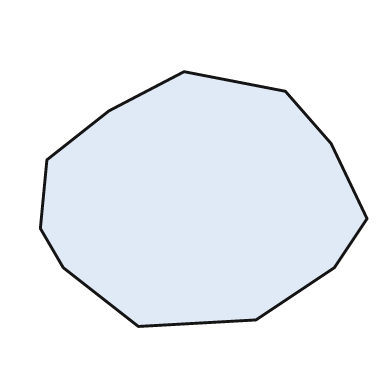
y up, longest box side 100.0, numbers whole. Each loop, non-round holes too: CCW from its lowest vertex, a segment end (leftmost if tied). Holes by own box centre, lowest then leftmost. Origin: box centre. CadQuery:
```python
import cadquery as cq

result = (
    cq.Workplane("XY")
    .moveTo(-20.0, -39.0)
    .lineTo(16.0, -37.0)
    .lineTo(40.0, -21.0)
    .lineTo(50.0, -6.0)
    .lineTo(39.0, 17.0)
    .lineTo(25.0, 33.0)
    .lineTo(-6.0, 39.0)
    .lineTo(-29.0, 27.0)
    .lineTo(-48.0, 12.0)
    .lineTo(-50.0, -9.0)
    .lineTo(-43.0, -21.0)
    .close()
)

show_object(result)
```